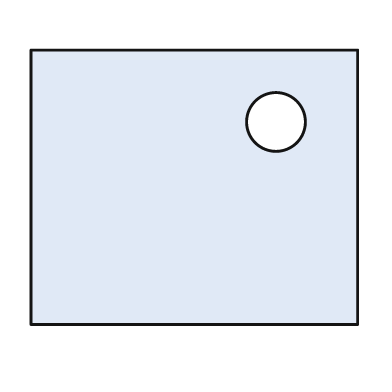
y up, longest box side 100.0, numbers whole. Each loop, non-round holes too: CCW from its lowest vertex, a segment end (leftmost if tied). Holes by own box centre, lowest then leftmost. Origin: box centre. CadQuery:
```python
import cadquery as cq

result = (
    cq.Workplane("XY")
    .moveTo(-50.0, -42.0)
    .lineTo(50.0, -42.0)
    .lineTo(50.0, 42.0)
    .lineTo(-50.0, 42.0)
    .close()
    .moveTo(25.0, 20.0)
    .circle(9.0)
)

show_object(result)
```